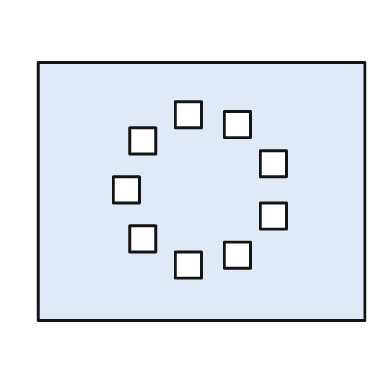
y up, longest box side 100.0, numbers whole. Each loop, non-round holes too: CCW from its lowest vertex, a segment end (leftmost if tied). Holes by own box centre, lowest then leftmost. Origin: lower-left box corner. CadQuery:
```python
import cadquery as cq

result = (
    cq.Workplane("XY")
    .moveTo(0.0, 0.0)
    .lineTo(100.0, 0.0)
    .lineTo(100.0, 79.0)
    .lineTo(0.0, 79.0)
    .close()
    .moveTo(42.0, 13.0)
    .lineTo(50.0, 13.0)
    .lineTo(50.0, 21.0)
    .lineTo(42.0, 21.0)
    .close()
    .moveTo(57.0, 16.0)
    .lineTo(65.0, 16.0)
    .lineTo(65.0, 24.0)
    .lineTo(57.0, 24.0)
    .close()
    .moveTo(28.0, 21.0)
    .lineTo(36.0, 21.0)
    .lineTo(36.0, 29.0)
    .lineTo(28.0, 29.0)
    .close()
    .moveTo(68.0, 28.0)
    .lineTo(76.0, 28.0)
    .lineTo(76.0, 36.0)
    .lineTo(68.0, 36.0)
    .close()
    .moveTo(23.0, 36.0)
    .lineTo(31.0, 36.0)
    .lineTo(31.0, 44.0)
    .lineTo(23.0, 44.0)
    .close()
    .moveTo(68.0, 44.0)
    .lineTo(76.0, 44.0)
    .lineTo(76.0, 52.0)
    .lineTo(68.0, 52.0)
    .close()
    .moveTo(28.0, 51.0)
    .lineTo(36.0, 51.0)
    .lineTo(36.0, 59.0)
    .lineTo(28.0, 59.0)
    .close()
    .moveTo(57.0, 56.0)
    .lineTo(65.0, 56.0)
    .lineTo(65.0, 64.0)
    .lineTo(57.0, 64.0)
    .close()
    .moveTo(42.0, 59.0)
    .lineTo(50.0, 59.0)
    .lineTo(50.0, 67.0)
    .lineTo(42.0, 67.0)
    .close()
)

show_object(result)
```